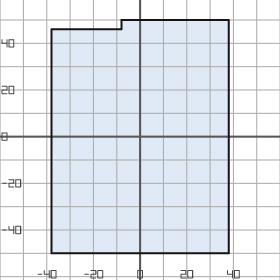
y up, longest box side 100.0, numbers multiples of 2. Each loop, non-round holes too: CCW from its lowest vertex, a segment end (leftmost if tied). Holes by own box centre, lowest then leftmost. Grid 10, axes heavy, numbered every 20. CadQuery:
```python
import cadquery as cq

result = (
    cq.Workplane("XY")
    .moveTo(-38.0, -50.0)
    .lineTo(38.0, -50.0)
    .lineTo(38.0, 50.0)
    .lineTo(-8.0, 50.0)
    .lineTo(-8.0, 46.0)
    .lineTo(-38.0, 46.0)
    .close()
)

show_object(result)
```